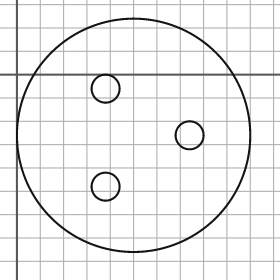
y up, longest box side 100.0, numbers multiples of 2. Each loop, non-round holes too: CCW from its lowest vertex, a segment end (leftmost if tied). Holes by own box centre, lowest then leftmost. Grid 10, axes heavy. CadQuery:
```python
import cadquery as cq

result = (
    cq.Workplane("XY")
    .moveTo(50.0, -26.0)
    .circle(50.0)
    .moveTo(38.0, -48.0)
    .circle(6.0)
    .moveTo(74.0, -26.0)
    .circle(6.0)
    .moveTo(38.0, -6.0)
    .circle(6.0)
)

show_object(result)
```